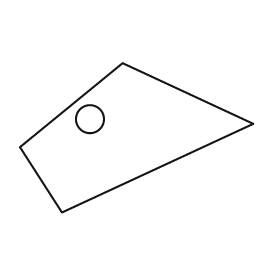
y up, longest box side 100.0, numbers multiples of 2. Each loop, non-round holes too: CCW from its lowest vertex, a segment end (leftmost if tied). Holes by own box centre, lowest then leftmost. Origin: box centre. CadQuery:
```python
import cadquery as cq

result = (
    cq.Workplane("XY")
    .moveTo(-32.0, -32.0)
    .lineTo(50.0, 6.0)
    .lineTo(-6.0, 32.0)
    .lineTo(-50.0, -4.0)
    .close()
    .moveTo(-20.0, 8.0)
    .circle(6.0)
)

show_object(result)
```